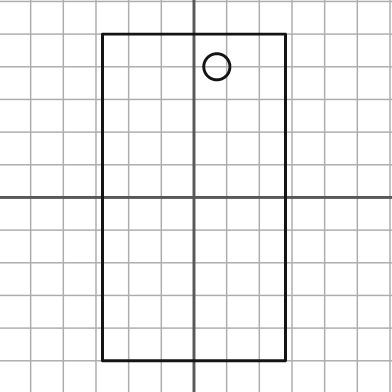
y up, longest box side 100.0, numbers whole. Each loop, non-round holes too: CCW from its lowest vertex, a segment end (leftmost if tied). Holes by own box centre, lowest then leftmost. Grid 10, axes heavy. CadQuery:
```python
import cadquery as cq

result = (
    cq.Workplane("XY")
    .moveTo(-28.0, -50.0)
    .lineTo(28.0, -50.0)
    .lineTo(28.0, 50.0)
    .lineTo(-28.0, 50.0)
    .close()
    .moveTo(7.0, 40.0)
    .circle(4.0)
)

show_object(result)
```